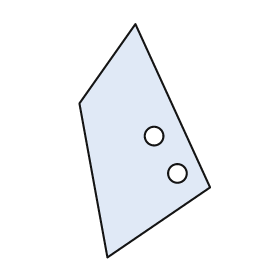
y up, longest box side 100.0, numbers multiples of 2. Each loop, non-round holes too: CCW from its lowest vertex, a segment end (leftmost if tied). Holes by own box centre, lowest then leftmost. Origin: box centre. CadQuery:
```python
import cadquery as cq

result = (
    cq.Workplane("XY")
    .moveTo(-16.0, -50.0)
    .lineTo(28.0, -20.0)
    .lineTo(-4.0, 50.0)
    .lineTo(-28.0, 16.0)
    .close()
    .moveTo(14.0, -14.0)
    .circle(4.0)
    .moveTo(4.0, 2.0)
    .circle(4.0)
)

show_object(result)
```